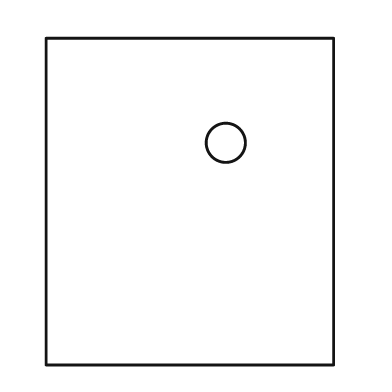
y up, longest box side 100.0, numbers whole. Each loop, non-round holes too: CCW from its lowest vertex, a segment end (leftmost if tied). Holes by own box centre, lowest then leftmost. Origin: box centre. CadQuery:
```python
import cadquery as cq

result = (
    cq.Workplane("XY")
    .moveTo(-44.0, -50.0)
    .lineTo(44.0, -50.0)
    .lineTo(44.0, 50.0)
    .lineTo(-44.0, 50.0)
    .close()
    .moveTo(11.0, 18.0)
    .circle(6.0)
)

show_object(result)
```